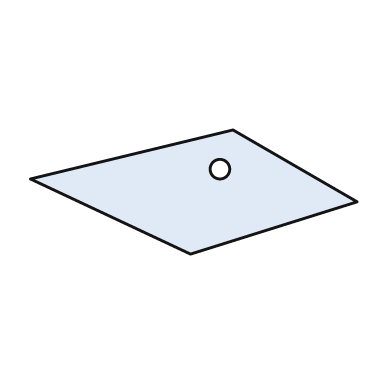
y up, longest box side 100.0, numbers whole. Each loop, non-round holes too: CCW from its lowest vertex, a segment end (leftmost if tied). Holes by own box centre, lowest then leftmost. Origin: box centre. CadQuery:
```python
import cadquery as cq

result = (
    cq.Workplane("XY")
    .moveTo(-1.0, -19.0)
    .lineTo(50.0, -3.0)
    .lineTo(12.0, 19.0)
    .lineTo(-50.0, 4.0)
    .close()
    .moveTo(8.0, 7.0)
    .circle(3.0)
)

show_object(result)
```